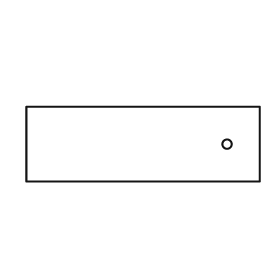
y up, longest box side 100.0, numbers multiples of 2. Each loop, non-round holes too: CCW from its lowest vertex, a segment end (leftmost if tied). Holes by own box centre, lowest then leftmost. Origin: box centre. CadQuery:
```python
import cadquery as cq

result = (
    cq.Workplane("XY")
    .moveTo(-50.0, -16.0)
    .lineTo(50.0, -16.0)
    .lineTo(50.0, 16.0)
    .lineTo(-50.0, 16.0)
    .close()
    .moveTo(36.0, 0.0)
    .circle(2.0)
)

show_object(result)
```